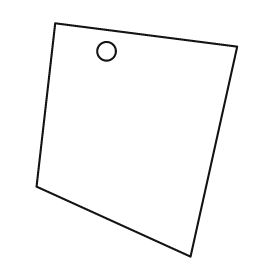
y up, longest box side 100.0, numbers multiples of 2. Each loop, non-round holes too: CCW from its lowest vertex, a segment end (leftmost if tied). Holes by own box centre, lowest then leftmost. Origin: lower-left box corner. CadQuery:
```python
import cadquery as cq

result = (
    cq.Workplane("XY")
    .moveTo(66.0, 0.0)
    .lineTo(86.0, 90.0)
    .lineTo(8.0, 100.0)
    .lineTo(0.0, 30.0)
    .close()
    .moveTo(30.0, 88.0)
    .circle(4.0)
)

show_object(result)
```